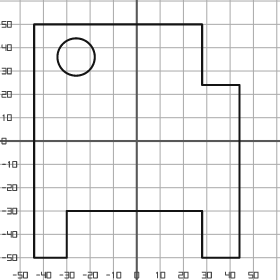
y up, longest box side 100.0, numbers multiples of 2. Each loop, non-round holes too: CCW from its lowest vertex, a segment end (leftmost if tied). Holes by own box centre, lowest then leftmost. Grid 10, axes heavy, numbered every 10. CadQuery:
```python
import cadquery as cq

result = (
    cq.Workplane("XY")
    .moveTo(-44.0, -50.0)
    .lineTo(-30.0, -50.0)
    .lineTo(-30.0, -30.0)
    .lineTo(28.0, -30.0)
    .lineTo(28.0, -50.0)
    .lineTo(44.0, -50.0)
    .lineTo(44.0, 24.0)
    .lineTo(28.0, 24.0)
    .lineTo(28.0, 50.0)
    .lineTo(-44.0, 50.0)
    .close()
    .moveTo(-26.0, 36.0)
    .circle(8.0)
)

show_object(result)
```